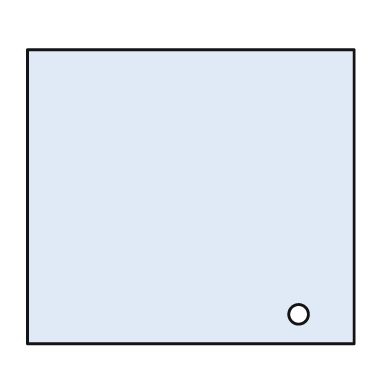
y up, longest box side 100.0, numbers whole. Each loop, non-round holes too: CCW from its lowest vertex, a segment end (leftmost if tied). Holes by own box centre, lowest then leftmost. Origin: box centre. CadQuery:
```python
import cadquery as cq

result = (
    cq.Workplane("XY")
    .moveTo(-50.0, -45.0)
    .lineTo(50.0, -45.0)
    .lineTo(50.0, 45.0)
    .lineTo(-50.0, 45.0)
    .close()
    .moveTo(33.0, -36.0)
    .circle(3.0)
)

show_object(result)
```